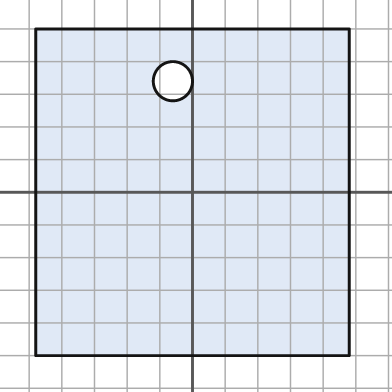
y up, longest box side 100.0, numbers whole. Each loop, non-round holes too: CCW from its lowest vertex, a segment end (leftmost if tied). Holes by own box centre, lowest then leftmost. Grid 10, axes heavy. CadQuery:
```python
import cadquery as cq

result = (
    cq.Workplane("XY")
    .moveTo(-48.0, -50.0)
    .lineTo(48.0, -50.0)
    .lineTo(48.0, 50.0)
    .lineTo(-48.0, 50.0)
    .close()
    .moveTo(-6.0, 34.0)
    .circle(6.0)
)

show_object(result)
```